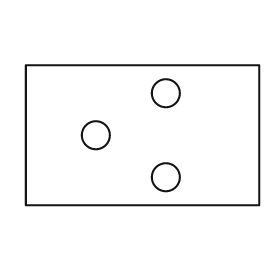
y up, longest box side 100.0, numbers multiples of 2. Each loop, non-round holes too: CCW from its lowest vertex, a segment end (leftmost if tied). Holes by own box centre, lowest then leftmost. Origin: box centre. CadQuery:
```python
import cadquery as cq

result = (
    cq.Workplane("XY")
    .moveTo(-50.0, -30.0)
    .lineTo(50.0, -30.0)
    .lineTo(50.0, 30.0)
    .lineTo(-50.0, 30.0)
    .close()
    .moveTo(10.0, -18.0)
    .circle(6.0)
    .moveTo(-20.0, 0.0)
    .circle(6.0)
    .moveTo(10.0, 18.0)
    .circle(6.0)
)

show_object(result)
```